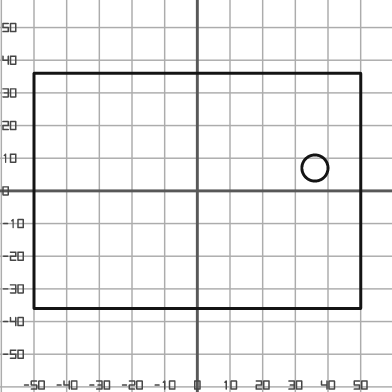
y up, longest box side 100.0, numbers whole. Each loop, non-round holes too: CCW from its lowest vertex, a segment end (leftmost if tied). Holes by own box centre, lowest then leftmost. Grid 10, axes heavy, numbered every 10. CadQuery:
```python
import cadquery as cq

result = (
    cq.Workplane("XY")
    .moveTo(-50.0, -36.0)
    .lineTo(50.0, -36.0)
    .lineTo(50.0, 36.0)
    .lineTo(-50.0, 36.0)
    .close()
    .moveTo(36.0, 7.0)
    .circle(4.0)
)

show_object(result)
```